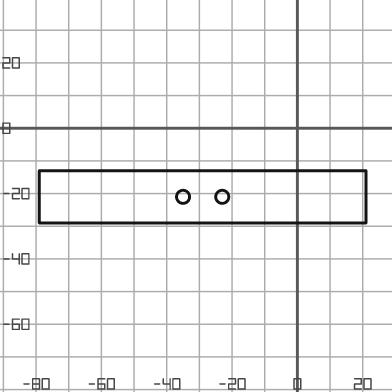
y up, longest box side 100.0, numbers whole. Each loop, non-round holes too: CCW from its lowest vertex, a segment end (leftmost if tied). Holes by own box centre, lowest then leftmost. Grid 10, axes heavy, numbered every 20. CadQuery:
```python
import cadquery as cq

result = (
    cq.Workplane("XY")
    .moveTo(-79.0, -29.0)
    .lineTo(21.0, -29.0)
    .lineTo(21.0, -13.0)
    .lineTo(-79.0, -13.0)
    .close()
    .moveTo(-35.0, -21.0)
    .circle(2.0)
    .moveTo(-23.0, -21.0)
    .circle(2.0)
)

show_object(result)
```